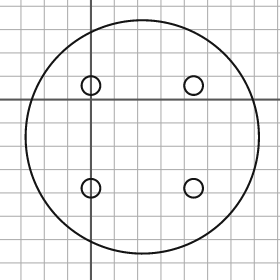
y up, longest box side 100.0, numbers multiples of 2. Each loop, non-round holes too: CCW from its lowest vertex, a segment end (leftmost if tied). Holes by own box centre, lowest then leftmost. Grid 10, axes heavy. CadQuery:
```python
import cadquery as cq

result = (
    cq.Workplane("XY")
    .moveTo(22.0, -16.0)
    .circle(50.0)
    .moveTo(0.0, -38.0)
    .circle(4.0)
    .moveTo(44.0, -38.0)
    .circle(4.0)
    .moveTo(0.0, 6.0)
    .circle(4.0)
    .moveTo(44.0, 6.0)
    .circle(4.0)
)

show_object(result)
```